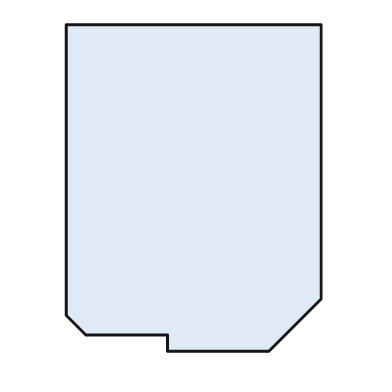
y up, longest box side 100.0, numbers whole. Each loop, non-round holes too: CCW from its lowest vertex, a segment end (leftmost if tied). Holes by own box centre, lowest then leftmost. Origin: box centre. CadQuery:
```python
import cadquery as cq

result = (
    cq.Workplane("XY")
    .moveTo(-8.0, -50.0)
    .lineTo(23.0, -50.0)
    .lineTo(39.0, -34.0)
    .lineTo(39.0, 50.0)
    .lineTo(-39.0, 50.0)
    .lineTo(-39.0, -39.0)
    .lineTo(-33.0, -45.0)
    .lineTo(-8.0, -45.0)
    .close()
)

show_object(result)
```